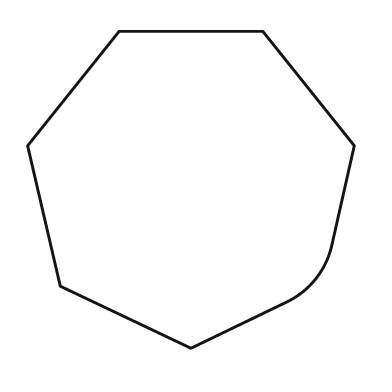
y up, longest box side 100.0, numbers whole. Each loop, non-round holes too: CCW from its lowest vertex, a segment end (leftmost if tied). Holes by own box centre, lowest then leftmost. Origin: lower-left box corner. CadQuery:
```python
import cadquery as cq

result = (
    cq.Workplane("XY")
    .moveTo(50.0, 0.0)
    .lineTo(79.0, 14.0)
    .threePointArc((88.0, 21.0), (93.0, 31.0))
    .lineTo(100.0, 62.0)
    .lineTo(72.0, 97.0)
    .lineTo(28.0, 97.0)
    .lineTo(0.0, 62.0)
    .lineTo(10.0, 19.0)
    .close()
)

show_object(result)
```